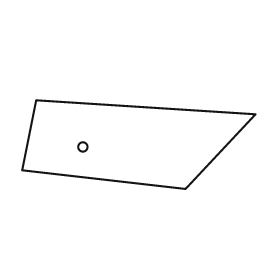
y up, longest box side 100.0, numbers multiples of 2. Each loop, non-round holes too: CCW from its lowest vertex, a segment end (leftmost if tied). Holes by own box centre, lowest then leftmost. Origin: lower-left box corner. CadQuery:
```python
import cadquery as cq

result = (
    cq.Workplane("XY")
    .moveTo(70.0, 0.0)
    .lineTo(100.0, 32.0)
    .lineTo(6.0, 38.0)
    .lineTo(0.0, 8.0)
    .close()
    .moveTo(26.0, 18.0)
    .circle(2.0)
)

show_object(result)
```